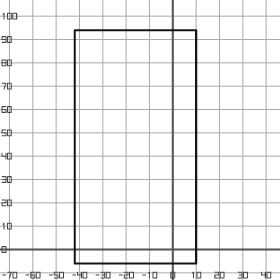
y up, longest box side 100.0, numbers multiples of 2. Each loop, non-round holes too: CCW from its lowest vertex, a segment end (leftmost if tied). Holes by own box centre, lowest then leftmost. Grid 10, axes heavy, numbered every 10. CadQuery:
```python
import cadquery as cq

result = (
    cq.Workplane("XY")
    .moveTo(-42.0, -6.0)
    .lineTo(10.0, -6.0)
    .lineTo(10.0, 94.0)
    .lineTo(-42.0, 94.0)
    .close()
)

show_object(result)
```